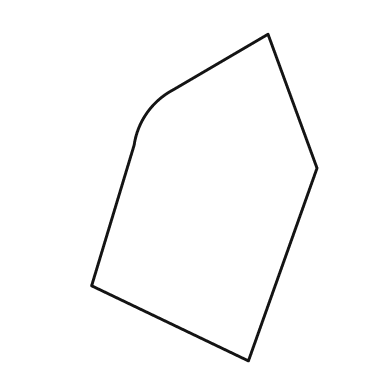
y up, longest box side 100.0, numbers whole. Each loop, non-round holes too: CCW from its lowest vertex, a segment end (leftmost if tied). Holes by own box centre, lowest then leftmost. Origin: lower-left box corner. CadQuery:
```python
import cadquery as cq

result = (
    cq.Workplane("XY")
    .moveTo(48.0, 0.0)
    .lineTo(69.0, 59.0)
    .lineTo(54.0, 100.0)
    .lineTo(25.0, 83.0)
    .threePointArc((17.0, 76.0), (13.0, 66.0))
    .lineTo(0.0, 23.0)
    .close()
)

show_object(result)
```